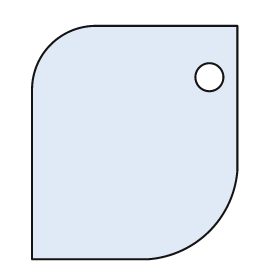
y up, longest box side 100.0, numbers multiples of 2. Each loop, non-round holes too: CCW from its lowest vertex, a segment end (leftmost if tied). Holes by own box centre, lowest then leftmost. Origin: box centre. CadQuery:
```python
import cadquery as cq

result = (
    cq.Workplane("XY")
    .moveTo(-44.0, -50.0)
    .lineTo(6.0, -50.0)
    .threePointArc((32.0, -38.0), (44.0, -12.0))
    .lineTo(44.0, 50.0)
    .lineTo(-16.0, 50.0)
    .threePointArc((-36.0, 42.0), (-44.0, 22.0))
    .close()
    .moveTo(32.0, 28.0)
    .circle(6.0)
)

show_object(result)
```